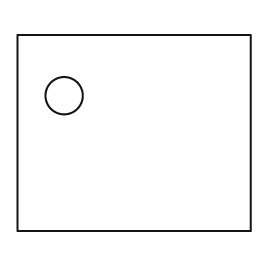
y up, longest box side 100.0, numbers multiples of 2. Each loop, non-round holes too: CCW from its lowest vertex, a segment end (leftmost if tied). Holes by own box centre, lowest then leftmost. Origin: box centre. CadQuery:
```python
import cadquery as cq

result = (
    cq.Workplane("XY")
    .moveTo(-50.0, -42.0)
    .lineTo(50.0, -42.0)
    .lineTo(50.0, 42.0)
    .lineTo(-50.0, 42.0)
    .close()
    .moveTo(-30.0, 16.0)
    .circle(8.0)
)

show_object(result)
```